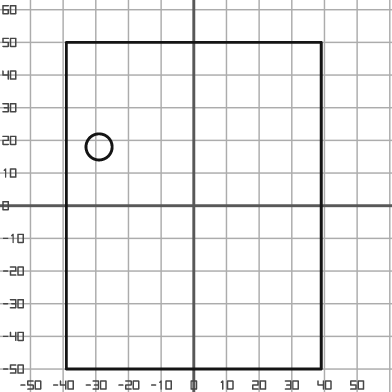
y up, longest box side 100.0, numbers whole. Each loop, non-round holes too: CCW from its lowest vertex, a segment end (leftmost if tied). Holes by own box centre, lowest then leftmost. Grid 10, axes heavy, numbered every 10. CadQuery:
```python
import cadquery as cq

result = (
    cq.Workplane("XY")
    .moveTo(-39.0, -50.0)
    .lineTo(39.0, -50.0)
    .lineTo(39.0, 50.0)
    .lineTo(-39.0, 50.0)
    .close()
    .moveTo(-29.0, 18.0)
    .circle(4.0)
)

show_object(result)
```